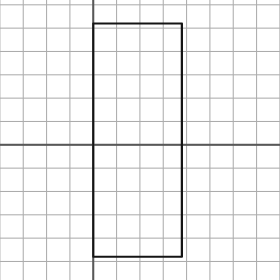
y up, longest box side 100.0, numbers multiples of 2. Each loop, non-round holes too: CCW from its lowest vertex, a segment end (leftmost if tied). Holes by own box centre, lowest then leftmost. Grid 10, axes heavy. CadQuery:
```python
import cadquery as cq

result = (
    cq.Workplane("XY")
    .moveTo(0.0, -48.0)
    .lineTo(38.0, -48.0)
    .lineTo(38.0, 52.0)
    .lineTo(0.0, 52.0)
    .close()
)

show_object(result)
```